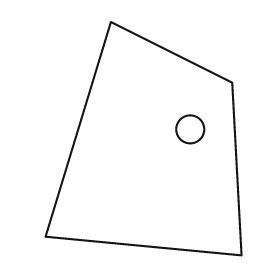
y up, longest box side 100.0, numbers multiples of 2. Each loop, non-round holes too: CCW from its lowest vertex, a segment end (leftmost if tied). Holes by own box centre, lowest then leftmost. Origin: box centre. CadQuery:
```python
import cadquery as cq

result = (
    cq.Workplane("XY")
    .moveTo(42.0, -50.0)
    .lineTo(38.0, 24.0)
    .lineTo(-14.0, 50.0)
    .lineTo(-42.0, -42.0)
    .close()
    .moveTo(20.0, 4.0)
    .circle(6.0)
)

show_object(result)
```